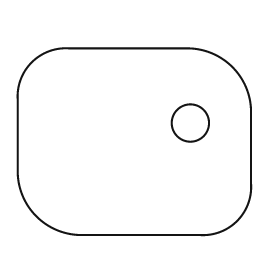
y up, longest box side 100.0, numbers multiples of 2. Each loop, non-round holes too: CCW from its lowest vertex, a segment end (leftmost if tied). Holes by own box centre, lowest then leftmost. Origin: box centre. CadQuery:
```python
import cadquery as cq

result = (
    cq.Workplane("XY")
    .moveTo(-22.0, -40.0)
    .lineTo(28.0, -40.0)
    .threePointArc((44.0, -34.0), (50.0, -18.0))
    .lineTo(50.0, 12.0)
    .threePointArc((42.0, 32.0), (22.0, 40.0))
    .lineTo(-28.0, 40.0)
    .threePointArc((-44.0, 34.0), (-50.0, 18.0))
    .lineTo(-50.0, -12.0)
    .threePointArc((-42.0, -32.0), (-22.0, -40.0))
    .close()
    .moveTo(24.0, 8.0)
    .circle(8.0)
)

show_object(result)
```